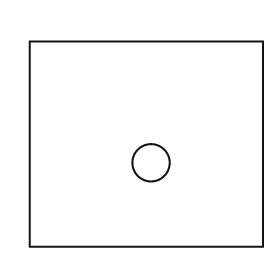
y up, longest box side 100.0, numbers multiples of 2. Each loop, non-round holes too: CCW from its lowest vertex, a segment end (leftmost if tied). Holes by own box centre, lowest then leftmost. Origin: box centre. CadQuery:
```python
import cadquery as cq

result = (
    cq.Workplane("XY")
    .moveTo(-50.0, -44.0)
    .lineTo(50.0, -44.0)
    .lineTo(50.0, 44.0)
    .lineTo(-50.0, 44.0)
    .close()
    .moveTo(2.0, -8.0)
    .circle(8.0)
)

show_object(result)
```